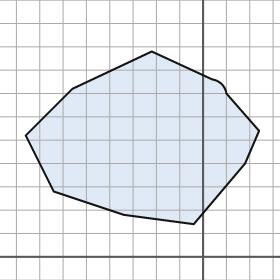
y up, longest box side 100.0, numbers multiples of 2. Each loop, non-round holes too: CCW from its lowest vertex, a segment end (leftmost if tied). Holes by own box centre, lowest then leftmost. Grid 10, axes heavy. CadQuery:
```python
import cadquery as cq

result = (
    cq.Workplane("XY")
    .moveTo(-4.0, 14.0)
    .lineTo(18.0, 40.0)
    .lineTo(24.0, 54.0)
    .lineTo(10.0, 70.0)
    .threePointArc((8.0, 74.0), (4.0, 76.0))
    .lineTo(-22.0, 88.0)
    .lineTo(-56.0, 72.0)
    .lineTo(-76.0, 52.0)
    .lineTo(-64.0, 28.0)
    .lineTo(-34.0, 18.0)
    .close()
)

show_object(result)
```